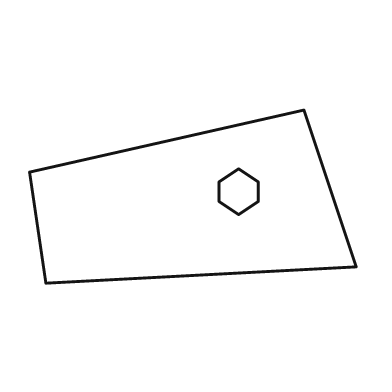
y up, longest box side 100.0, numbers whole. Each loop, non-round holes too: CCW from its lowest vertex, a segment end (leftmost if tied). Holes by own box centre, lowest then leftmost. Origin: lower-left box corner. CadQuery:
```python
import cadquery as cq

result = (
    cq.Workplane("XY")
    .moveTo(5.0, 0.0)
    .lineTo(100.0, 5.0)
    .lineTo(84.0, 53.0)
    .lineTo(0.0, 34.0)
    .close()
    .moveTo(64.0, 21.0)
    .lineTo(70.0, 25.0)
    .lineTo(70.0, 31.0)
    .lineTo(64.0, 35.0)
    .lineTo(58.0, 31.0)
    .lineTo(58.0, 25.0)
    .close()
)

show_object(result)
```